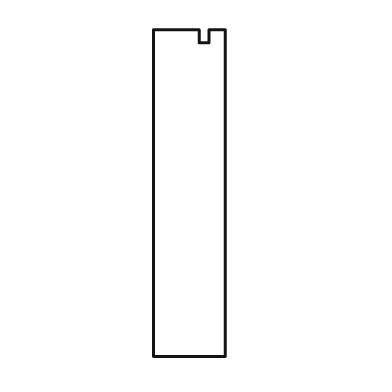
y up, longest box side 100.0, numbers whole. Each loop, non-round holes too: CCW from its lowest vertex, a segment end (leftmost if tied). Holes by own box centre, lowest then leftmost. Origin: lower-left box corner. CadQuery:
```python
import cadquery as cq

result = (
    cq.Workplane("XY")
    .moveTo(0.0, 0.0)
    .lineTo(22.0, 0.0)
    .lineTo(22.0, 100.0)
    .lineTo(17.0, 100.0)
    .lineTo(17.0, 96.0)
    .lineTo(14.0, 96.0)
    .lineTo(14.0, 100.0)
    .lineTo(0.0, 100.0)
    .close()
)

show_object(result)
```